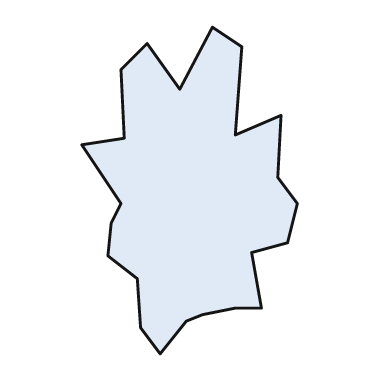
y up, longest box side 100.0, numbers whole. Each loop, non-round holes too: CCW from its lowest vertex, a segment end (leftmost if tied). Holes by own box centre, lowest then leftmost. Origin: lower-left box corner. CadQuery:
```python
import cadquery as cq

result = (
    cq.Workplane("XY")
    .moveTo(24.0, 0.0)
    .lineTo(32.0, 10.0)
    .lineTo(37.0, 12.0)
    .lineTo(47.0, 14.0)
    .lineTo(55.0, 14.0)
    .lineTo(52.0, 31.0)
    .lineTo(63.0, 34.0)
    .lineTo(66.0, 46.0)
    .lineTo(60.0, 54.0)
    .lineTo(61.0, 73.0)
    .lineTo(47.0, 67.0)
    .lineTo(49.0, 94.0)
    .lineTo(40.0, 100.0)
    .lineTo(30.0, 81.0)
    .lineTo(20.0, 95.0)
    .lineTo(12.0, 87.0)
    .lineTo(13.0, 66.0)
    .lineTo(0.0, 64.0)
    .lineTo(12.0, 46.0)
    .lineTo(9.0, 40.0)
    .lineTo(8.0, 30.0)
    .lineTo(17.0, 23.0)
    .lineTo(18.0, 8.0)
    .close()
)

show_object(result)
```